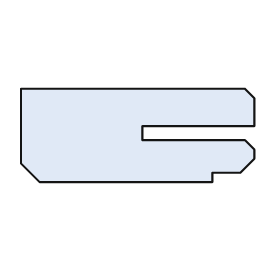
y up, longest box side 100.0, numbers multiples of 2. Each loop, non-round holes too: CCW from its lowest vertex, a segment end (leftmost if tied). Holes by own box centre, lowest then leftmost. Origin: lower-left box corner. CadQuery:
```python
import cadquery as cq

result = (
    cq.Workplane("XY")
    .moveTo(8.0, 0.0)
    .lineTo(82.0, 0.0)
    .lineTo(82.0, 4.0)
    .lineTo(94.0, 4.0)
    .lineTo(100.0, 10.0)
    .lineTo(100.0, 14.0)
    .lineTo(96.0, 18.0)
    .lineTo(52.0, 18.0)
    .lineTo(52.0, 24.0)
    .lineTo(100.0, 24.0)
    .lineTo(100.0, 36.0)
    .lineTo(96.0, 40.0)
    .lineTo(0.0, 40.0)
    .lineTo(0.0, 8.0)
    .close()
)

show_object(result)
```